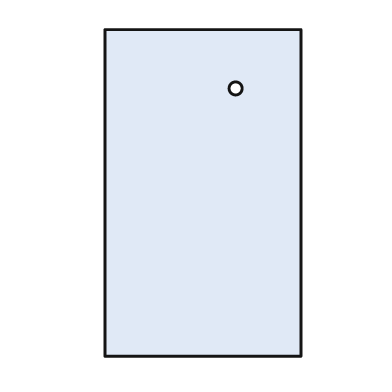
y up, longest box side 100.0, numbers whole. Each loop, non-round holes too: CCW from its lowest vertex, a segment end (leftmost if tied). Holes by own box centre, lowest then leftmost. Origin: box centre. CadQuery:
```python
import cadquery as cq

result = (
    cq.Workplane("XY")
    .moveTo(-30.0, -50.0)
    .lineTo(30.0, -50.0)
    .lineTo(30.0, 50.0)
    .lineTo(-30.0, 50.0)
    .close()
    .moveTo(10.0, 32.0)
    .circle(2.0)
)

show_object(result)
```